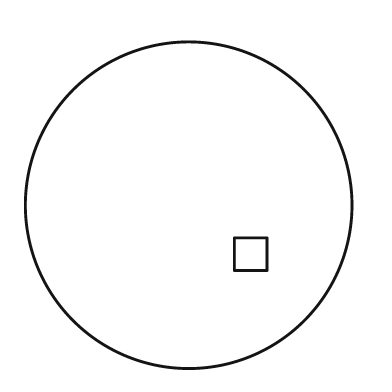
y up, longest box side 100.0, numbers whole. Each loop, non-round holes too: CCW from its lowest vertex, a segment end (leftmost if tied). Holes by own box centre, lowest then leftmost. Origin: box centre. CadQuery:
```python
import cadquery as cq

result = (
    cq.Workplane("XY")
    .moveTo(0.0, 0.0)
    .circle(50.0)
    .moveTo(14.0, -20.0)
    .lineTo(24.0, -20.0)
    .lineTo(24.0, -10.0)
    .lineTo(14.0, -10.0)
    .close()
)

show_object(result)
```